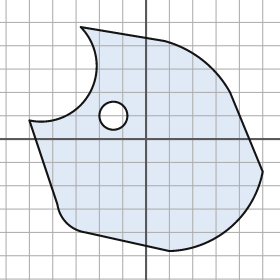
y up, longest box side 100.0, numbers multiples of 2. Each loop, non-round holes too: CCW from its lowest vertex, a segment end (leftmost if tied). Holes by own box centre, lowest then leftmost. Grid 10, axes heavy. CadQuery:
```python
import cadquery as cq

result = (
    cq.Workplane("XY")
    .moveTo(10.0, -48.0)
    .threePointArc((36.0, -38.0), (50.0, -14.0))
    .lineTo(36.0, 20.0)
    .threePointArc((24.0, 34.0), (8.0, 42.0))
    .lineTo(-28.0, 48.0)
    .threePointArc((-24.0, 20.0), (-50.0, 8.0))
    .lineTo(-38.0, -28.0)
    .threePointArc((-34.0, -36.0), (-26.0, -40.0))
    .close()
    .moveTo(-14.0, 10.0)
    .circle(6.0)
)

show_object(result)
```